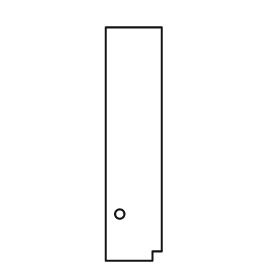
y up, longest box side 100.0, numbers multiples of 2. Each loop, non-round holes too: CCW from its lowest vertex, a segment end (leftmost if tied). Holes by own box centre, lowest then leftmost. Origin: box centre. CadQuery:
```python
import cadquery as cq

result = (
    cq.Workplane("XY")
    .moveTo(-12.0, -50.0)
    .lineTo(8.0, -50.0)
    .lineTo(8.0, -46.0)
    .lineTo(12.0, -46.0)
    .lineTo(12.0, 50.0)
    .lineTo(-12.0, 50.0)
    .close()
    .moveTo(-6.0, -30.0)
    .circle(2.0)
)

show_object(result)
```